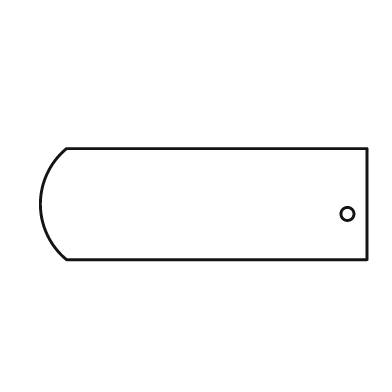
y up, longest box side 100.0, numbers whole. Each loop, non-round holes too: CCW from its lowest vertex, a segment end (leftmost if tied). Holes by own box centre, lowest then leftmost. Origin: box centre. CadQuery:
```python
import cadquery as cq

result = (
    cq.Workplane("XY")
    .moveTo(-42.0, -17.0)
    .lineTo(50.0, -17.0)
    .lineTo(50.0, 17.0)
    .lineTo(-42.0, 17.0)
    .threePointArc((-50.0, 0.0), (-42.0, -17.0))
    .close()
    .moveTo(44.0, -3.0)
    .circle(2.0)
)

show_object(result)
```